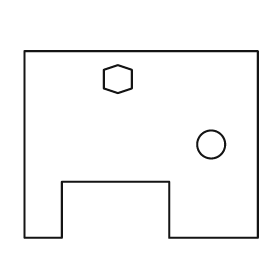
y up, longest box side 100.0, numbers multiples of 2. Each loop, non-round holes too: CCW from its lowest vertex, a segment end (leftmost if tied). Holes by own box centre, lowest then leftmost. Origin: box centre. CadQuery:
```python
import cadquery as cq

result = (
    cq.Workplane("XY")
    .moveTo(-50.0, -40.0)
    .lineTo(-34.0, -40.0)
    .lineTo(-34.0, -16.0)
    .lineTo(12.0, -16.0)
    .lineTo(12.0, -40.0)
    .lineTo(50.0, -40.0)
    .lineTo(50.0, 40.0)
    .lineTo(-50.0, 40.0)
    .close()
    .moveTo(30.0, 0.0)
    .circle(6.0)
    .moveTo(-10.0, 22.0)
    .lineTo(-4.0, 24.0)
    .lineTo(-4.0, 32.0)
    .lineTo(-10.0, 34.0)
    .lineTo(-16.0, 32.0)
    .lineTo(-16.0, 24.0)
    .close()
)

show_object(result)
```